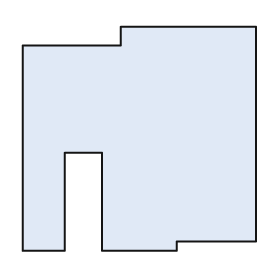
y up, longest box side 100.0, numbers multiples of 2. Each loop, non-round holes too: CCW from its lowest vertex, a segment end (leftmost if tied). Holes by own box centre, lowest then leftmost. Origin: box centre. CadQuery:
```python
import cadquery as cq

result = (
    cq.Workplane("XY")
    .moveTo(-50.0, -48.0)
    .lineTo(-32.0, -48.0)
    .lineTo(-32.0, -6.0)
    .lineTo(-16.0, -6.0)
    .lineTo(-16.0, -48.0)
    .lineTo(16.0, -48.0)
    .lineTo(16.0, -44.0)
    .lineTo(50.0, -44.0)
    .lineTo(50.0, 48.0)
    .lineTo(-8.0, 48.0)
    .lineTo(-8.0, 40.0)
    .lineTo(-50.0, 40.0)
    .close()
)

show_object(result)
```